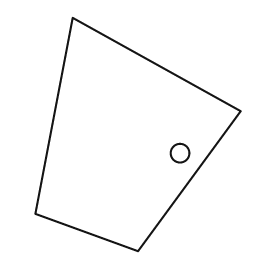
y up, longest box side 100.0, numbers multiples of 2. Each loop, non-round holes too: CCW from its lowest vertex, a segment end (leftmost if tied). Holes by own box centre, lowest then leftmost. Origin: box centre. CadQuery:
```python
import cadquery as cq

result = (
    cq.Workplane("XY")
    .moveTo(0.0, -50.0)
    .lineTo(44.0, 10.0)
    .lineTo(-28.0, 50.0)
    .lineTo(-44.0, -34.0)
    .close()
    .moveTo(18.0, -8.0)
    .circle(4.0)
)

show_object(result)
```